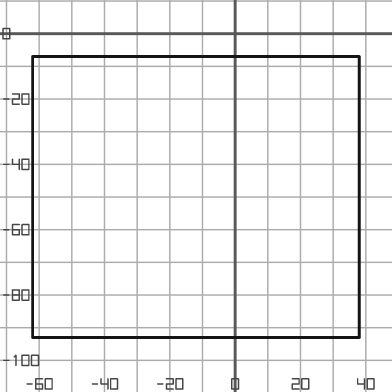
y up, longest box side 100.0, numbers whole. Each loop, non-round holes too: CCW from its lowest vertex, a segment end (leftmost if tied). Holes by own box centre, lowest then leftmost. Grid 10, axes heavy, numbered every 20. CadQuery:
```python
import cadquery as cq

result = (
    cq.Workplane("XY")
    .moveTo(-62.0, -93.0)
    .lineTo(38.0, -93.0)
    .lineTo(38.0, -7.0)
    .lineTo(-62.0, -7.0)
    .close()
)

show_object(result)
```